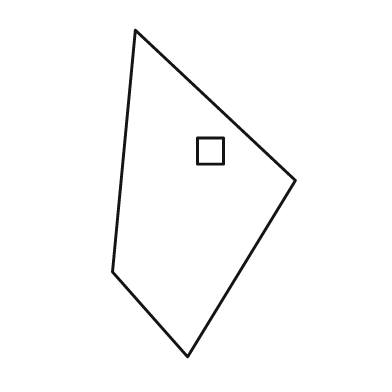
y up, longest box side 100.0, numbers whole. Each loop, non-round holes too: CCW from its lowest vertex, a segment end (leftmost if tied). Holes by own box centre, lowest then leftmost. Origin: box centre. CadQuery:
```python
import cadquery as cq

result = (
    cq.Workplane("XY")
    .moveTo(-5.0, -50.0)
    .lineTo(28.0, 4.0)
    .lineTo(-21.0, 50.0)
    .lineTo(-28.0, -24.0)
    .close()
    .moveTo(-2.0, 9.0)
    .lineTo(6.0, 9.0)
    .lineTo(6.0, 17.0)
    .lineTo(-2.0, 17.0)
    .close()
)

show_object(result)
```